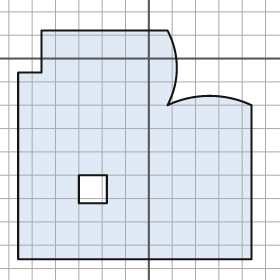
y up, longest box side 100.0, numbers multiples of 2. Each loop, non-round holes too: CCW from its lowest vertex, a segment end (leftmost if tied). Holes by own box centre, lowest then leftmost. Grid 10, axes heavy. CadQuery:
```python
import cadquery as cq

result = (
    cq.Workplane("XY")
    .moveTo(-56.0, -86.0)
    .lineTo(44.0, -86.0)
    .lineTo(44.0, -20.0)
    .threePointArc((26.0, -16.0), (8.0, -20.0))
    .threePointArc((12.0, -4.0), (8.0, 12.0))
    .lineTo(-46.0, 12.0)
    .lineTo(-46.0, -6.0)
    .lineTo(-56.0, -6.0)
    .close()
    .moveTo(-30.0, -62.0)
    .lineTo(-18.0, -62.0)
    .lineTo(-18.0, -50.0)
    .lineTo(-30.0, -50.0)
    .close()
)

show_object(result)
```